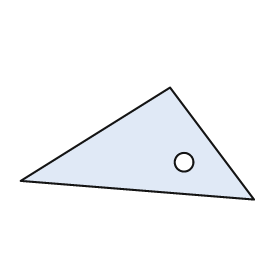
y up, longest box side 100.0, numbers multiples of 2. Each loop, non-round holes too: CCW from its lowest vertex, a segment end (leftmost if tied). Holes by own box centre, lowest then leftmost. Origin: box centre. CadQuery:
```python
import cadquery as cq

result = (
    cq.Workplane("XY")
    .moveTo(50.0, -24.0)
    .lineTo(14.0, 24.0)
    .lineTo(-50.0, -16.0)
    .close()
    .moveTo(20.0, -8.0)
    .circle(4.0)
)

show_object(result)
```